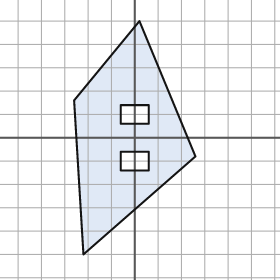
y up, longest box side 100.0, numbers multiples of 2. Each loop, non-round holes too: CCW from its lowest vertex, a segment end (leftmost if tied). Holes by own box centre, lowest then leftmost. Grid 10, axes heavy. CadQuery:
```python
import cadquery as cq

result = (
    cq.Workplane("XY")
    .moveTo(-22.0, -50.0)
    .lineTo(26.0, -8.0)
    .lineTo(2.0, 50.0)
    .lineTo(-26.0, 16.0)
    .close()
    .moveTo(-6.0, -14.0)
    .lineTo(6.0, -14.0)
    .lineTo(6.0, -6.0)
    .lineTo(-6.0, -6.0)
    .close()
    .moveTo(-6.0, 6.0)
    .lineTo(6.0, 6.0)
    .lineTo(6.0, 14.0)
    .lineTo(-6.0, 14.0)
    .close()
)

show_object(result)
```